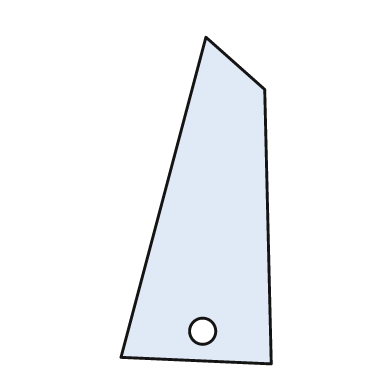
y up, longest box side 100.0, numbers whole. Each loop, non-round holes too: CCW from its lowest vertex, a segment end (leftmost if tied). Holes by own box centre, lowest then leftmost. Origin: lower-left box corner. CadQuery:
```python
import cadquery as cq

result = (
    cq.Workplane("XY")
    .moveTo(46.0, 0.0)
    .lineTo(44.0, 84.0)
    .lineTo(26.0, 100.0)
    .lineTo(0.0, 2.0)
    .close()
    .moveTo(25.0, 10.0)
    .circle(4.0)
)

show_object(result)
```